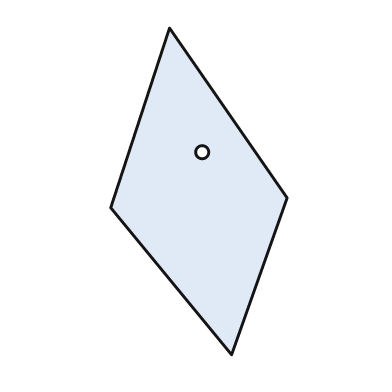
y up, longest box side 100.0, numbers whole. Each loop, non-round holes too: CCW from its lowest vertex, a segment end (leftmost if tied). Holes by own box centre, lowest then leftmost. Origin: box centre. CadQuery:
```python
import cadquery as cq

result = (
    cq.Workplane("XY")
    .moveTo(10.0, -50.0)
    .lineTo(27.0, -2.0)
    .lineTo(-9.0, 50.0)
    .lineTo(-27.0, -5.0)
    .close()
    .moveTo(1.0, 12.0)
    .circle(2.0)
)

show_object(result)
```